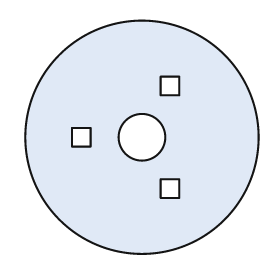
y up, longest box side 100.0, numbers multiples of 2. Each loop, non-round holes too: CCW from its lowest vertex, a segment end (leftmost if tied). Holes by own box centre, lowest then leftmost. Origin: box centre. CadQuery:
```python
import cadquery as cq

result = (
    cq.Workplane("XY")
    .moveTo(0.0, 0.0)
    .circle(50.0)
    .moveTo(8.0, -26.0)
    .lineTo(16.0, -26.0)
    .lineTo(16.0, -18.0)
    .lineTo(8.0, -18.0)
    .close()
    .moveTo(-30.0, -4.0)
    .lineTo(-22.0, -4.0)
    .lineTo(-22.0, 4.0)
    .lineTo(-30.0, 4.0)
    .close()
    .moveTo(0.0, 0.0)
    .circle(10.0)
    .moveTo(8.0, 18.0)
    .lineTo(16.0, 18.0)
    .lineTo(16.0, 26.0)
    .lineTo(8.0, 26.0)
    .close()
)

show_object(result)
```